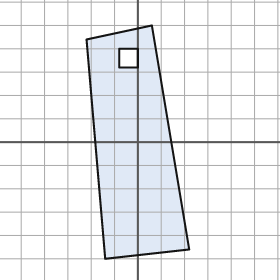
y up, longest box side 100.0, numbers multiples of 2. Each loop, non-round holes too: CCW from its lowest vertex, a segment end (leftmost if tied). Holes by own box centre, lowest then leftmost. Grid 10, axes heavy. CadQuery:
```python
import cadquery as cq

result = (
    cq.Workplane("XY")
    .moveTo(-14.0, -50.0)
    .lineTo(22.0, -46.0)
    .lineTo(6.0, 50.0)
    .lineTo(-22.0, 44.0)
    .close()
    .moveTo(-8.0, 32.0)
    .lineTo(0.0, 32.0)
    .lineTo(0.0, 40.0)
    .lineTo(-8.0, 40.0)
    .close()
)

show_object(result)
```